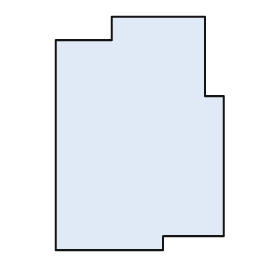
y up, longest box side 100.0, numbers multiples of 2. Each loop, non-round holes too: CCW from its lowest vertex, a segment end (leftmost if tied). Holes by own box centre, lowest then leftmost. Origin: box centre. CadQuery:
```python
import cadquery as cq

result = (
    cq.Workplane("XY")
    .moveTo(-36.0, -50.0)
    .lineTo(10.0, -50.0)
    .lineTo(10.0, -44.0)
    .lineTo(36.0, -44.0)
    .lineTo(36.0, 16.0)
    .lineTo(28.0, 16.0)
    .lineTo(28.0, 50.0)
    .lineTo(-12.0, 50.0)
    .lineTo(-12.0, 40.0)
    .lineTo(-36.0, 40.0)
    .close()
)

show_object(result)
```